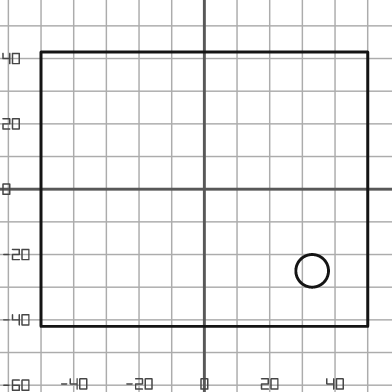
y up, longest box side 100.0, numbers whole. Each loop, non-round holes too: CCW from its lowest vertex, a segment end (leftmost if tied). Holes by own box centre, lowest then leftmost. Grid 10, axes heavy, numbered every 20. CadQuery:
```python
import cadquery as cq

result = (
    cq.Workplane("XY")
    .moveTo(-50.0, -42.0)
    .lineTo(50.0, -42.0)
    .lineTo(50.0, 42.0)
    .lineTo(-50.0, 42.0)
    .close()
    .moveTo(33.0, -25.0)
    .circle(5.0)
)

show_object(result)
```